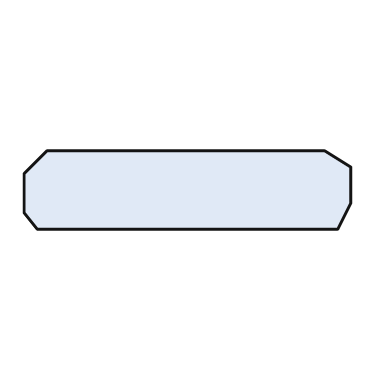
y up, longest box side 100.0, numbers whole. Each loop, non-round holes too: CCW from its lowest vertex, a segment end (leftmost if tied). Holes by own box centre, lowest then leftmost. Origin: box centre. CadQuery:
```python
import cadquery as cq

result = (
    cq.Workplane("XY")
    .moveTo(-46.0, -12.0)
    .lineTo(46.0, -12.0)
    .lineTo(50.0, -4.0)
    .lineTo(50.0, 7.0)
    .lineTo(42.0, 12.0)
    .lineTo(-43.0, 12.0)
    .lineTo(-50.0, 5.0)
    .lineTo(-50.0, -7.0)
    .close()
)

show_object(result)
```